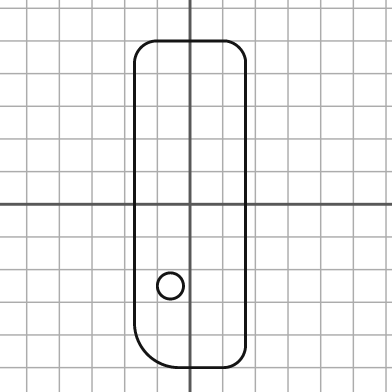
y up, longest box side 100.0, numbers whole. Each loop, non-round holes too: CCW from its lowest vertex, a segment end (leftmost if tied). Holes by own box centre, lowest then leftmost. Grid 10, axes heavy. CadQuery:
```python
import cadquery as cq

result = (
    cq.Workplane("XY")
    .moveTo(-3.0, -50.0)
    .lineTo(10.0, -50.0)
    .threePointArc((15.0, -48.0), (17.0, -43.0))
    .lineTo(17.0, 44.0)
    .threePointArc((15.0, 48.0), (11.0, 50.0))
    .lineTo(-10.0, 50.0)
    .threePointArc((-15.0, 48.0), (-17.0, 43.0))
    .lineTo(-17.0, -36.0)
    .threePointArc((-13.0, -46.0), (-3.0, -50.0))
    .close()
    .moveTo(-6.0, -25.0)
    .circle(4.0)
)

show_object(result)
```